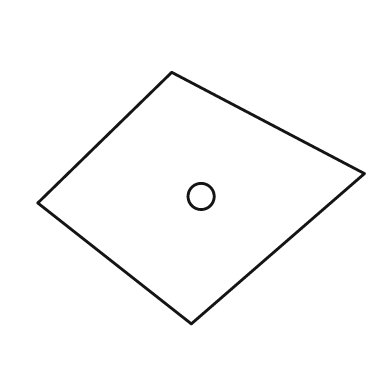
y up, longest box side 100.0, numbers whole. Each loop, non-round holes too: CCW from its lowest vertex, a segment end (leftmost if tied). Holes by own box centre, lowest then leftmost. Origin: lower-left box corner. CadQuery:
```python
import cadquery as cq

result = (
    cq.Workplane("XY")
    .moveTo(47.0, 0.0)
    .lineTo(100.0, 46.0)
    .lineTo(41.0, 77.0)
    .lineTo(0.0, 37.0)
    .close()
    .moveTo(50.0, 39.0)
    .circle(4.0)
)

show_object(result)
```